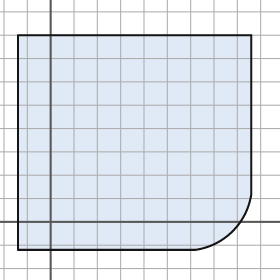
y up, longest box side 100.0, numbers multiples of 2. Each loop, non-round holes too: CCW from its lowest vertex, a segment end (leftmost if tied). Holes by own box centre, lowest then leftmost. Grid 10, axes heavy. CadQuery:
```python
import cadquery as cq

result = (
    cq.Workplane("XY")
    .moveTo(-14.0, -12.0)
    .lineTo(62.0, -12.0)
    .threePointArc((78.0, -4.0), (86.0, 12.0))
    .lineTo(86.0, 80.0)
    .lineTo(-14.0, 80.0)
    .close()
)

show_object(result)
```